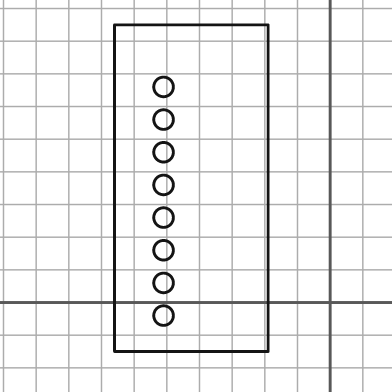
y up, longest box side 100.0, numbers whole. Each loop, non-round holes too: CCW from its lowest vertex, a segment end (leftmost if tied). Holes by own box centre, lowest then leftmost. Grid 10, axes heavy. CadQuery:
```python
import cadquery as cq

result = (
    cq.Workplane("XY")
    .moveTo(-66.0, -15.0)
    .lineTo(-19.0, -15.0)
    .lineTo(-19.0, 85.0)
    .lineTo(-66.0, 85.0)
    .close()
    .moveTo(-51.0, -4.0)
    .circle(3.0)
    .moveTo(-51.0, 6.0)
    .circle(3.0)
    .moveTo(-51.0, 16.0)
    .circle(3.0)
    .moveTo(-51.0, 26.0)
    .circle(3.0)
    .moveTo(-51.0, 36.0)
    .circle(3.0)
    .moveTo(-51.0, 46.0)
    .circle(3.0)
    .moveTo(-51.0, 56.0)
    .circle(3.0)
    .moveTo(-51.0, 66.0)
    .circle(3.0)
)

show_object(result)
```